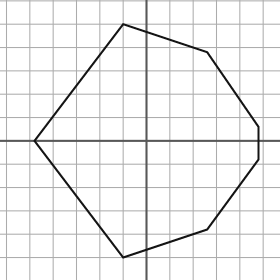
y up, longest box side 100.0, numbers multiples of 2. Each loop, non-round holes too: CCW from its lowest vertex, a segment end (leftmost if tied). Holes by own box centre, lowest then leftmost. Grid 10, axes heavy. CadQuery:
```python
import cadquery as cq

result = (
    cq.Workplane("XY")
    .moveTo(-10.0, -50.0)
    .lineTo(26.0, -38.0)
    .lineTo(48.0, -8.0)
    .lineTo(48.0, 6.0)
    .lineTo(26.0, 38.0)
    .lineTo(-10.0, 50.0)
    .lineTo(-48.0, 0.0)
    .close()
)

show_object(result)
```